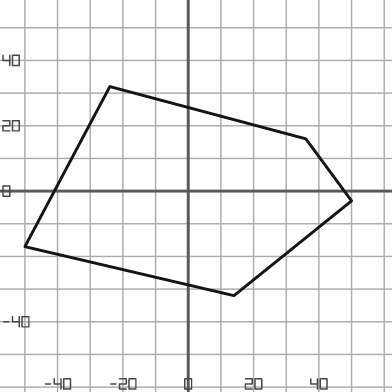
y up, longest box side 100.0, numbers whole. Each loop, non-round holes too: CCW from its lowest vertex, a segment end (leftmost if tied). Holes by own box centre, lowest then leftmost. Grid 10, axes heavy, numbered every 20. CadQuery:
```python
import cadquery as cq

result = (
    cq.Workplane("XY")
    .moveTo(14.0, -32.0)
    .lineTo(50.0, -3.0)
    .lineTo(36.0, 16.0)
    .lineTo(-24.0, 32.0)
    .lineTo(-50.0, -17.0)
    .close()
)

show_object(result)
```